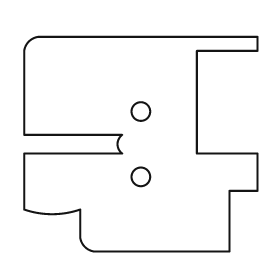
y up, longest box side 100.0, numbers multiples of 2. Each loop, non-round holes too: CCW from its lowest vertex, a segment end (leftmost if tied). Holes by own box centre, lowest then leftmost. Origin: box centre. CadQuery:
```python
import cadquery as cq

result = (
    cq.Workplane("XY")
    .moveTo(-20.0, -46.0)
    .lineTo(38.0, -46.0)
    .lineTo(38.0, -20.0)
    .lineTo(50.0, -20.0)
    .lineTo(50.0, -4.0)
    .lineTo(24.0, -4.0)
    .lineTo(24.0, 40.0)
    .lineTo(50.0, 40.0)
    .lineTo(50.0, 46.0)
    .lineTo(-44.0, 46.0)
    .threePointArc((-48.0, 44.0), (-50.0, 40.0))
    .lineTo(-50.0, 4.0)
    .lineTo(-8.0, 4.0)
    .threePointArc((-10.0, 0.0), (-8.0, -4.0))
    .lineTo(-50.0, -4.0)
    .lineTo(-50.0, -28.0)
    .threePointArc((-38.0, -30.0), (-26.0, -28.0))
    .lineTo(-26.0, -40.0)
    .threePointArc((-24.0, -44.0), (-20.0, -46.0))
    .close()
    .moveTo(0.0, -14.0)
    .circle(4.0)
    .moveTo(0.0, 14.0)
    .circle(4.0)
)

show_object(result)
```